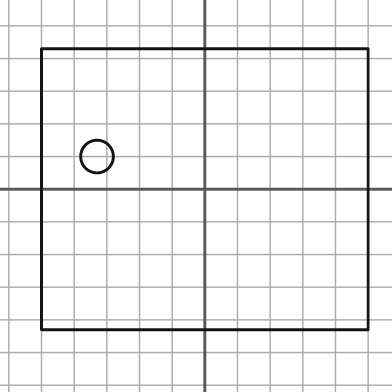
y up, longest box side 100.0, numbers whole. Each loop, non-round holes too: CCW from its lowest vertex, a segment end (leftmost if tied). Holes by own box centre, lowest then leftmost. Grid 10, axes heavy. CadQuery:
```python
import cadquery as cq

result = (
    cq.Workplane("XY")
    .moveTo(-50.0, -43.0)
    .lineTo(50.0, -43.0)
    .lineTo(50.0, 43.0)
    .lineTo(-50.0, 43.0)
    .close()
    .moveTo(-33.0, 10.0)
    .circle(5.0)
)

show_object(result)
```